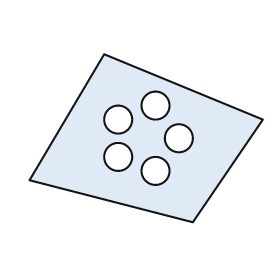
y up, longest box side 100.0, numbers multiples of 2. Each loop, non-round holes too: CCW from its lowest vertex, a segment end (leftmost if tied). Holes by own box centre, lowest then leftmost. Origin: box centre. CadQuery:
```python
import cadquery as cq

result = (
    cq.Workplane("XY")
    .moveTo(20.0, -36.0)
    .lineTo(50.0, 8.0)
    .lineTo(-18.0, 36.0)
    .lineTo(-50.0, -18.0)
    .close()
    .moveTo(4.0, -14.0)
    .circle(6.0)
    .moveTo(-12.0, -8.0)
    .circle(6.0)
    .moveTo(14.0, 0.0)
    .circle(6.0)
    .moveTo(-12.0, 8.0)
    .circle(6.0)
    .moveTo(4.0, 14.0)
    .circle(6.0)
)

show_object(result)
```